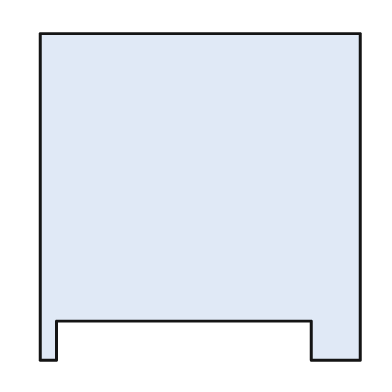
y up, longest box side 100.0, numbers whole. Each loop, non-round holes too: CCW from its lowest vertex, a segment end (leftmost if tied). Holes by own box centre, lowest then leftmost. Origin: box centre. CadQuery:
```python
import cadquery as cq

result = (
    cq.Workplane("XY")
    .moveTo(-49.0, -50.0)
    .lineTo(-44.0, -50.0)
    .lineTo(-44.0, -38.0)
    .lineTo(34.0, -38.0)
    .lineTo(34.0, -50.0)
    .lineTo(49.0, -50.0)
    .lineTo(49.0, 50.0)
    .lineTo(-49.0, 50.0)
    .close()
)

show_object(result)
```